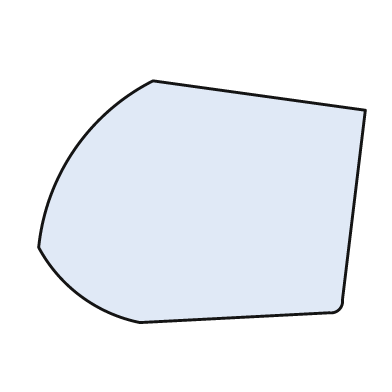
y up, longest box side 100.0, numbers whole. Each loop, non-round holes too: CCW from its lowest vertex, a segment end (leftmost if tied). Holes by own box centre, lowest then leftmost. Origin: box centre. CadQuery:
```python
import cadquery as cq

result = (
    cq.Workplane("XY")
    .moveTo(-19.0, -37.0)
    .lineTo(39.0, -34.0)
    .threePointArc((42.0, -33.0), (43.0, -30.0))
    .lineTo(50.0, 28.0)
    .lineTo(-15.0, 37.0)
    .threePointArc((-39.0, 16.0), (-50.0, -14.0))
    .threePointArc((-37.0, -29.0), (-19.0, -37.0))
    .close()
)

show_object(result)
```